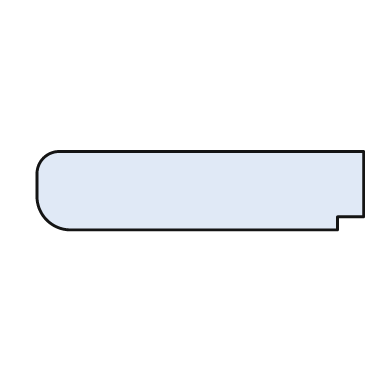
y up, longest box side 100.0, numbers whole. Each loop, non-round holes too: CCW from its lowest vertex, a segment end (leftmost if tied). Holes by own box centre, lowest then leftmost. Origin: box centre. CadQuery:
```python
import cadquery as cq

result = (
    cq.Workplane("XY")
    .moveTo(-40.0, -12.0)
    .lineTo(42.0, -12.0)
    .lineTo(42.0, -8.0)
    .lineTo(50.0, -8.0)
    .lineTo(50.0, 12.0)
    .lineTo(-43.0, 12.0)
    .threePointArc((-48.0, 10.0), (-50.0, 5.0))
    .lineTo(-50.0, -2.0)
    .threePointArc((-47.0, -9.0), (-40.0, -12.0))
    .close()
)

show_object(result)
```